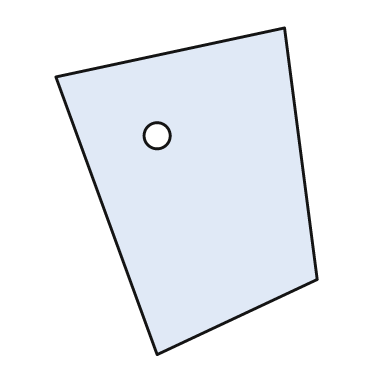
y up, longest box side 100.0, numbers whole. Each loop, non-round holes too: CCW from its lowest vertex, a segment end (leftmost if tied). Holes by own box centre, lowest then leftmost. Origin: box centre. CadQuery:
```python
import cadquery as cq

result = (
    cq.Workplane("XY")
    .moveTo(-9.0, -50.0)
    .lineTo(40.0, -27.0)
    .lineTo(30.0, 50.0)
    .lineTo(-40.0, 35.0)
    .close()
    .moveTo(-9.0, 17.0)
    .circle(4.0)
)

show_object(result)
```